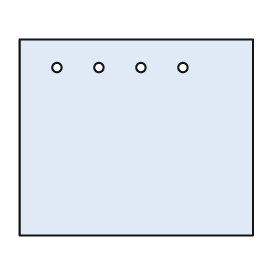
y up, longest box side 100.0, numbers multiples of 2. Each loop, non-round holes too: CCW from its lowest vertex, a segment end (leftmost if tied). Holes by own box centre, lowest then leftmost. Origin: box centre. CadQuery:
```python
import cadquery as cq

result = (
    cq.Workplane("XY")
    .moveTo(-50.0, -42.0)
    .lineTo(50.0, -42.0)
    .lineTo(50.0, 42.0)
    .lineTo(-50.0, 42.0)
    .close()
    .moveTo(-34.0, 30.0)
    .circle(2.0)
    .moveTo(-16.0, 30.0)
    .circle(2.0)
    .moveTo(2.0, 30.0)
    .circle(2.0)
    .moveTo(20.0, 30.0)
    .circle(2.0)
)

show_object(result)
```